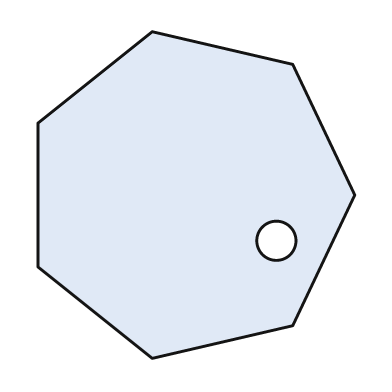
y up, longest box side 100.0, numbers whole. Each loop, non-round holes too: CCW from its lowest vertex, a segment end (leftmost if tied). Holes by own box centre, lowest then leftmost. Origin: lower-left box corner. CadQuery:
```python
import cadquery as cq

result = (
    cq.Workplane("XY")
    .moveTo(35.0, 0.0)
    .lineTo(78.0, 10.0)
    .lineTo(97.0, 50.0)
    .lineTo(78.0, 90.0)
    .lineTo(35.0, 100.0)
    .lineTo(0.0, 72.0)
    .lineTo(0.0, 28.0)
    .close()
    .moveTo(73.0, 36.0)
    .circle(6.0)
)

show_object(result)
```